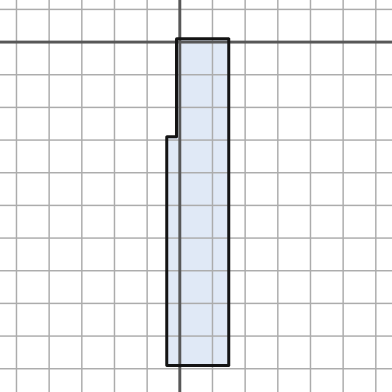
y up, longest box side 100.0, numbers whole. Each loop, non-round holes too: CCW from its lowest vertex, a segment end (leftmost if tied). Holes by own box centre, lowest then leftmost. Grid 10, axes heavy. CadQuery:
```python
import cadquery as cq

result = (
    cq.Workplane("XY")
    .moveTo(-4.0, -99.0)
    .lineTo(15.0, -99.0)
    .lineTo(15.0, 1.0)
    .lineTo(-1.0, 1.0)
    .lineTo(-1.0, -29.0)
    .lineTo(-4.0, -29.0)
    .close()
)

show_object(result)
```